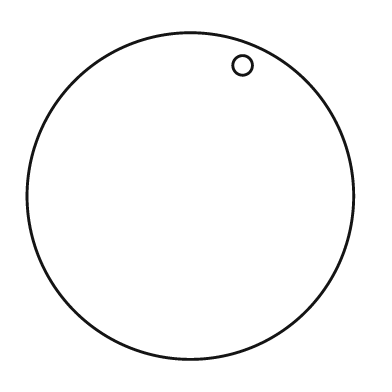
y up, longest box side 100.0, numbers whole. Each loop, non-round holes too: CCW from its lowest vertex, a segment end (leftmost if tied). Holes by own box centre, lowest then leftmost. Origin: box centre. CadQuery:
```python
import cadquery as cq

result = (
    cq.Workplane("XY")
    .moveTo(0.0, 0.0)
    .circle(50.0)
    .moveTo(16.0, 40.0)
    .circle(3.0)
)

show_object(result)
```